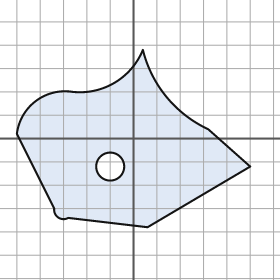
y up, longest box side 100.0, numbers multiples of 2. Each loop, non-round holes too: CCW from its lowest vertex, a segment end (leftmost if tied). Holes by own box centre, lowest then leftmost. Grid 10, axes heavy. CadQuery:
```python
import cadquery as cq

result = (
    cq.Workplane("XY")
    .moveTo(6.0, -38.0)
    .lineTo(50.0, -12.0)
    .lineTo(32.0, 4.0)
    .threePointArc((14.0, 18.0), (4.0, 38.0))
    .threePointArc((-8.0, 24.0), (-26.0, 20.0))
    .threePointArc((-42.0, 16.0), (-50.0, 2.0))
    .lineTo(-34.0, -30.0)
    .threePointArc((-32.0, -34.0), (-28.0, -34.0))
    .close()
    .moveTo(-10.0, -12.0)
    .circle(6.0)
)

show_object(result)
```